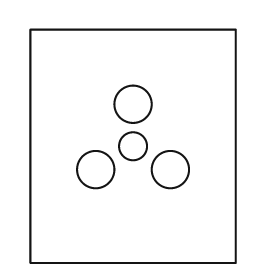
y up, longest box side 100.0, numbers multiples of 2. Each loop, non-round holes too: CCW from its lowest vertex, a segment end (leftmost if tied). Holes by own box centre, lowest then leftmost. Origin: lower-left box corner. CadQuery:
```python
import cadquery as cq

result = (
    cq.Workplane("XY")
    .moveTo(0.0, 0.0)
    .lineTo(88.0, 0.0)
    .lineTo(88.0, 100.0)
    .lineTo(0.0, 100.0)
    .close()
    .moveTo(28.0, 40.0)
    .circle(8.0)
    .moveTo(60.0, 40.0)
    .circle(8.0)
    .moveTo(44.0, 50.0)
    .circle(6.0)
    .moveTo(44.0, 68.0)
    .circle(8.0)
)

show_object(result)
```